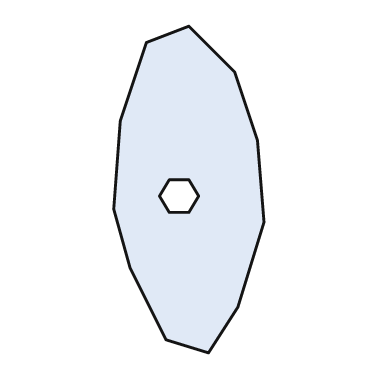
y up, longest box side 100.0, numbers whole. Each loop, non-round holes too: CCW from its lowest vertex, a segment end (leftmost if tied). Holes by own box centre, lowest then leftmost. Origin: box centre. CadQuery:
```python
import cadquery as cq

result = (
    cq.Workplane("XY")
    .moveTo(6.0, -50.0)
    .lineTo(15.0, -36.0)
    .lineTo(23.0, -10.0)
    .lineTo(21.0, 15.0)
    .lineTo(14.0, 36.0)
    .lineTo(0.0, 50.0)
    .lineTo(-13.0, 45.0)
    .lineTo(-21.0, 21.0)
    .lineTo(-23.0, -6.0)
    .lineTo(-18.0, -24.0)
    .lineTo(-7.0, -46.0)
    .close()
    .moveTo(-6.0, -7.0)
    .lineTo(0.0, -7.0)
    .lineTo(3.0, -2.0)
    .lineTo(0.0, 3.0)
    .lineTo(-6.0, 3.0)
    .lineTo(-9.0, -2.0)
    .close()
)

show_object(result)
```